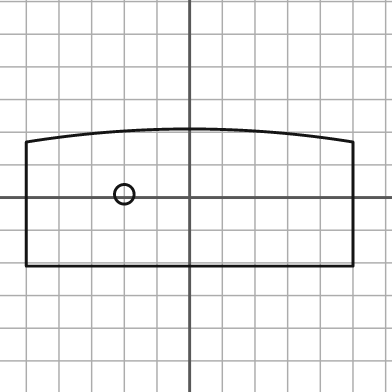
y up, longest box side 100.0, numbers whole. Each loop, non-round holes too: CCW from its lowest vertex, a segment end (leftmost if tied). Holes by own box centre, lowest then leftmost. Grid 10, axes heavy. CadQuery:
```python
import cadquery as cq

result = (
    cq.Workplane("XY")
    .moveTo(-50.0, -21.0)
    .lineTo(50.0, -21.0)
    .lineTo(50.0, 17.0)
    .threePointArc((0.0, 21.0), (-50.0, 17.0))
    .close()
    .moveTo(-20.0, 1.0)
    .circle(3.0)
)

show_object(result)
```